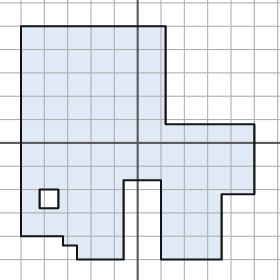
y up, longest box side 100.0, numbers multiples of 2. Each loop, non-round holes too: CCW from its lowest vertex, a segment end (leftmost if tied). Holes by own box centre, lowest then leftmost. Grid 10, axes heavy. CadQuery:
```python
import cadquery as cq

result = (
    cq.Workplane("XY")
    .moveTo(-26.0, -50.0)
    .lineTo(-6.0, -50.0)
    .lineTo(-6.0, -16.0)
    .lineTo(10.0, -16.0)
    .lineTo(10.0, -50.0)
    .lineTo(36.0, -50.0)
    .lineTo(36.0, -22.0)
    .lineTo(50.0, -22.0)
    .lineTo(50.0, 8.0)
    .lineTo(12.0, 8.0)
    .lineTo(12.0, 50.0)
    .lineTo(-50.0, 50.0)
    .lineTo(-50.0, -40.0)
    .lineTo(-32.0, -40.0)
    .lineTo(-32.0, -44.0)
    .lineTo(-26.0, -44.0)
    .close()
    .moveTo(-42.0, -28.0)
    .lineTo(-34.0, -28.0)
    .lineTo(-34.0, -20.0)
    .lineTo(-42.0, -20.0)
    .close()
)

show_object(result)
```